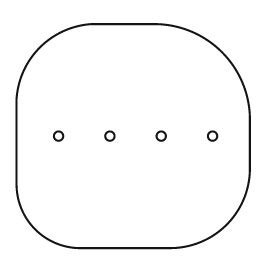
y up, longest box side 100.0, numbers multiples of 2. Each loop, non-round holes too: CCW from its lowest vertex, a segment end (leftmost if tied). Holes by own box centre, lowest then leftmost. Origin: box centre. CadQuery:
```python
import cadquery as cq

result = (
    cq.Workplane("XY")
    .moveTo(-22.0, -48.0)
    .lineTo(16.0, -48.0)
    .threePointArc((40.0, -38.0), (50.0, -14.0))
    .lineTo(50.0, 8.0)
    .threePointArc((38.0, 36.0), (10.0, 48.0))
    .lineTo(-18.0, 48.0)
    .threePointArc((-40.0, 38.0), (-50.0, 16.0))
    .lineTo(-50.0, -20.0)
    .threePointArc((-42.0, -40.0), (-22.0, -48.0))
    .close()
    .moveTo(-32.0, 0.0)
    .circle(2.0)
    .moveTo(-10.0, 0.0)
    .circle(2.0)
    .moveTo(12.0, 0.0)
    .circle(2.0)
    .moveTo(34.0, 0.0)
    .circle(2.0)
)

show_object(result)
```